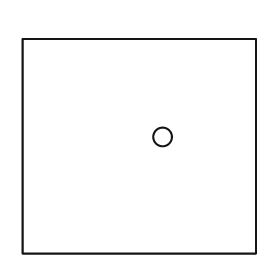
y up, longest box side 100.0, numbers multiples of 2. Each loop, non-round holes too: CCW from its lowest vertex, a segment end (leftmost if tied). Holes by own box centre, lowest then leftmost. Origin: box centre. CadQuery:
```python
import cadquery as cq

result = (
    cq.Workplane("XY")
    .moveTo(-50.0, -46.0)
    .lineTo(50.0, -46.0)
    .lineTo(50.0, 46.0)
    .lineTo(-50.0, 46.0)
    .close()
    .moveTo(10.0, 4.0)
    .circle(4.0)
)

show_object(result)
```